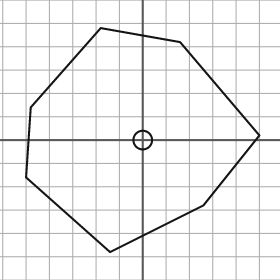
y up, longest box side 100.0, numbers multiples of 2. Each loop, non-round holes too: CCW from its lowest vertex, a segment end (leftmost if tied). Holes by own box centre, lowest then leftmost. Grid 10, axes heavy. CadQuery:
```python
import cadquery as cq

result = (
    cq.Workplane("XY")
    .moveTo(-14.0, -48.0)
    .lineTo(26.0, -28.0)
    .lineTo(50.0, 2.0)
    .lineTo(16.0, 42.0)
    .lineTo(-18.0, 48.0)
    .lineTo(-48.0, 14.0)
    .lineTo(-50.0, -16.0)
    .close()
    .moveTo(0.0, 0.0)
    .circle(4.0)
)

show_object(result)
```